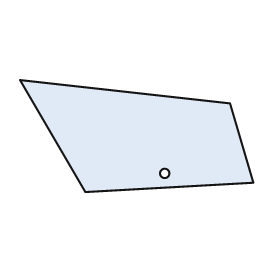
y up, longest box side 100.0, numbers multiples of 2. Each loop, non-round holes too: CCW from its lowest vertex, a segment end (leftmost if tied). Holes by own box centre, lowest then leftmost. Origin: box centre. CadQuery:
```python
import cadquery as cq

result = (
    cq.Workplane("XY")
    .moveTo(-22.0, -24.0)
    .lineTo(50.0, -20.0)
    .lineTo(40.0, 14.0)
    .lineTo(-50.0, 24.0)
    .close()
    .moveTo(12.0, -16.0)
    .circle(2.0)
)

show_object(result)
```